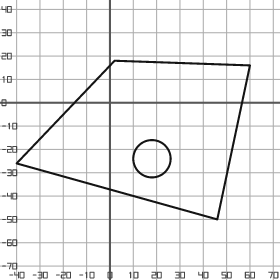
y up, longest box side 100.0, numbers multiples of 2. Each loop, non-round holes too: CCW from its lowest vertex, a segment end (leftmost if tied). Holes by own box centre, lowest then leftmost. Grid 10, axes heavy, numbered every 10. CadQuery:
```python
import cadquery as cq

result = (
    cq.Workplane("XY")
    .moveTo(46.0, -50.0)
    .lineTo(60.0, 16.0)
    .lineTo(2.0, 18.0)
    .lineTo(-40.0, -26.0)
    .close()
    .moveTo(18.0, -24.0)
    .circle(8.0)
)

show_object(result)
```